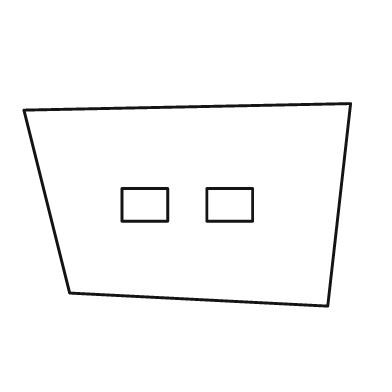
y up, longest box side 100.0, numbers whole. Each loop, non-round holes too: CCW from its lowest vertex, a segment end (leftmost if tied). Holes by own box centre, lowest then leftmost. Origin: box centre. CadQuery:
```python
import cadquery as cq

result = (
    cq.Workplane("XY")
    .moveTo(43.0, -31.0)
    .lineTo(50.0, 31.0)
    .lineTo(-50.0, 29.0)
    .lineTo(-36.0, -27.0)
    .close()
    .moveTo(-20.0, -5.0)
    .lineTo(-6.0, -5.0)
    .lineTo(-6.0, 5.0)
    .lineTo(-20.0, 5.0)
    .close()
    .moveTo(6.0, -5.0)
    .lineTo(20.0, -5.0)
    .lineTo(20.0, 5.0)
    .lineTo(6.0, 5.0)
    .close()
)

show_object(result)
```